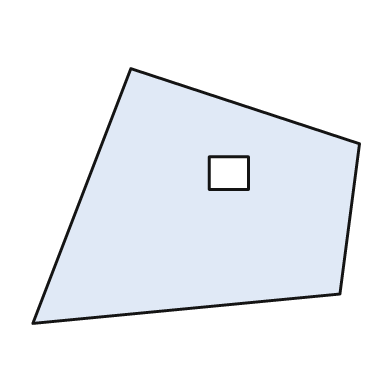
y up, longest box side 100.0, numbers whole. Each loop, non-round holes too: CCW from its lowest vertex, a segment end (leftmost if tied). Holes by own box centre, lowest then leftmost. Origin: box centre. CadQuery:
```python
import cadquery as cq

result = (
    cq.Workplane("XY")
    .moveTo(-50.0, -39.0)
    .lineTo(44.0, -30.0)
    .lineTo(50.0, 16.0)
    .lineTo(-20.0, 39.0)
    .close()
    .moveTo(4.0, 2.0)
    .lineTo(16.0, 2.0)
    .lineTo(16.0, 12.0)
    .lineTo(4.0, 12.0)
    .close()
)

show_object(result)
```